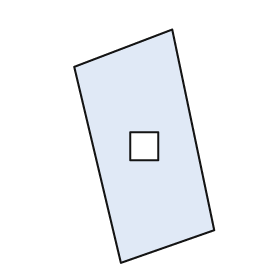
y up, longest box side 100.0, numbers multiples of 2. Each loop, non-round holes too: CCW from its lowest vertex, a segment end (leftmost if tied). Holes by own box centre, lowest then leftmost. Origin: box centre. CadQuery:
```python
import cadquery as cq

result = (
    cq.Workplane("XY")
    .moveTo(-10.0, -50.0)
    .lineTo(30.0, -36.0)
    .lineTo(12.0, 50.0)
    .lineTo(-30.0, 34.0)
    .close()
    .moveTo(-6.0, -6.0)
    .lineTo(6.0, -6.0)
    .lineTo(6.0, 6.0)
    .lineTo(-6.0, 6.0)
    .close()
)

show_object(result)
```